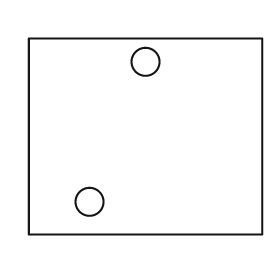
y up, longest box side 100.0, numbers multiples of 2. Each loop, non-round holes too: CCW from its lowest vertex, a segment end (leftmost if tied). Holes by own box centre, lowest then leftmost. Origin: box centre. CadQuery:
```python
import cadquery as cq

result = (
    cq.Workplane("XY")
    .moveTo(-50.0, -42.0)
    .lineTo(50.0, -42.0)
    .lineTo(50.0, 42.0)
    .lineTo(-50.0, 42.0)
    .close()
    .moveTo(-24.0, -28.0)
    .circle(6.0)
    .moveTo(0.0, 32.0)
    .circle(6.0)
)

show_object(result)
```